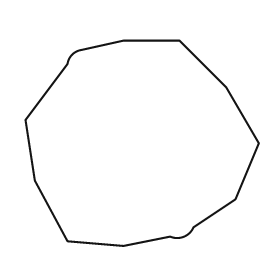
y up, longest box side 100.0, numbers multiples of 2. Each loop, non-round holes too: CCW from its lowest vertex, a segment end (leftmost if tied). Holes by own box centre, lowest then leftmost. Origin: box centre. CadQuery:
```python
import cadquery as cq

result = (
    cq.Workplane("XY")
    .moveTo(-8.0, -44.0)
    .lineTo(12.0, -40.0)
    .threePointArc((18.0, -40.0), (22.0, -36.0))
    .lineTo(40.0, -24.0)
    .lineTo(50.0, 0.0)
    .lineTo(36.0, 24.0)
    .lineTo(16.0, 44.0)
    .lineTo(-8.0, 44.0)
    .lineTo(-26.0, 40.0)
    .threePointArc((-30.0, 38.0), (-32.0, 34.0))
    .lineTo(-50.0, 10.0)
    .lineTo(-46.0, -16.0)
    .lineTo(-32.0, -42.0)
    .close()
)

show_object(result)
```